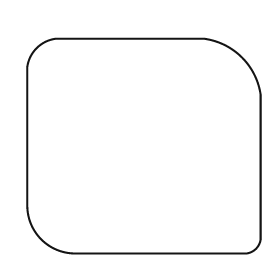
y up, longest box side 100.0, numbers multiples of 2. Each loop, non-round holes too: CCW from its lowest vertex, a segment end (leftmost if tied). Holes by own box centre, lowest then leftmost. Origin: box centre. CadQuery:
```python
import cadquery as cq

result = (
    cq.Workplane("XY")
    .moveTo(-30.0, -46.0)
    .lineTo(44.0, -46.0)
    .threePointArc((48.0, -44.0), (50.0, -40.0))
    .lineTo(50.0, 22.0)
    .threePointArc((42.0, 38.0), (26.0, 46.0))
    .lineTo(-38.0, 46.0)
    .threePointArc((-46.0, 42.0), (-50.0, 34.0))
    .lineTo(-50.0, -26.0)
    .threePointArc((-44.0, -40.0), (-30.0, -46.0))
    .close()
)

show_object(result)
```